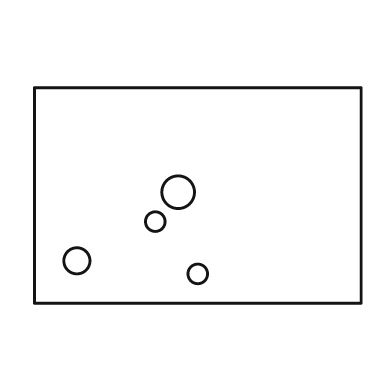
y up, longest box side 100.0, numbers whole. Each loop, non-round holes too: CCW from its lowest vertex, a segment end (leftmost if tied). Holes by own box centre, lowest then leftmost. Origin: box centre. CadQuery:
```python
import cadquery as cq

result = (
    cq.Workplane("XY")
    .moveTo(-50.0, -33.0)
    .lineTo(50.0, -33.0)
    .lineTo(50.0, 33.0)
    .lineTo(-50.0, 33.0)
    .close()
    .moveTo(0.0, -24.0)
    .circle(3.0)
    .moveTo(-37.0, -20.0)
    .circle(4.0)
    .moveTo(-13.0, -8.0)
    .circle(3.0)
    .moveTo(-6.0, 1.0)
    .circle(5.0)
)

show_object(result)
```